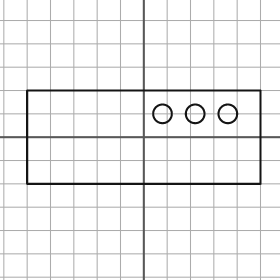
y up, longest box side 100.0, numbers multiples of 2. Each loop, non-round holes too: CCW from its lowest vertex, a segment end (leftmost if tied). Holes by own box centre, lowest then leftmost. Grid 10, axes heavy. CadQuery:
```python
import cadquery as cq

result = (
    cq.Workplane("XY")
    .moveTo(-50.0, -20.0)
    .lineTo(50.0, -20.0)
    .lineTo(50.0, 20.0)
    .lineTo(-50.0, 20.0)
    .close()
    .moveTo(8.0, 10.0)
    .circle(4.0)
    .moveTo(22.0, 10.0)
    .circle(4.0)
    .moveTo(36.0, 10.0)
    .circle(4.0)
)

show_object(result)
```